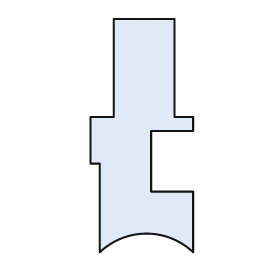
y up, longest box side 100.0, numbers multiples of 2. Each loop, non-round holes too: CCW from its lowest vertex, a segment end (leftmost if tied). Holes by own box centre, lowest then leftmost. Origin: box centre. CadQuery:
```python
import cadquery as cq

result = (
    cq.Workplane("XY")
    .moveTo(-18.0, -50.0)
    .threePointArc((2.0, -42.0), (22.0, -50.0))
    .lineTo(22.0, -24.0)
    .lineTo(4.0, -24.0)
    .lineTo(4.0, 2.0)
    .lineTo(22.0, 2.0)
    .lineTo(22.0, 8.0)
    .lineTo(14.0, 8.0)
    .lineTo(14.0, 50.0)
    .lineTo(-12.0, 50.0)
    .lineTo(-12.0, 8.0)
    .lineTo(-22.0, 8.0)
    .lineTo(-22.0, -12.0)
    .lineTo(-18.0, -12.0)
    .close()
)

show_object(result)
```